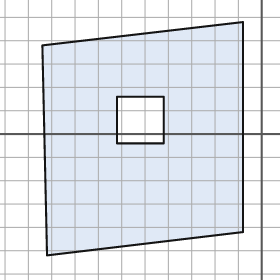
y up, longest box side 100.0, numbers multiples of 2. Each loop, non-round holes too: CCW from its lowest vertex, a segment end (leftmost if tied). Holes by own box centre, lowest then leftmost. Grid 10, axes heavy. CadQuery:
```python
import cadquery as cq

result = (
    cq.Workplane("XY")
    .moveTo(-92.0, -52.0)
    .lineTo(-8.0, -42.0)
    .lineTo(-8.0, 48.0)
    .lineTo(-94.0, 38.0)
    .close()
    .moveTo(-62.0, -4.0)
    .lineTo(-42.0, -4.0)
    .lineTo(-42.0, 16.0)
    .lineTo(-62.0, 16.0)
    .close()
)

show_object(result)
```